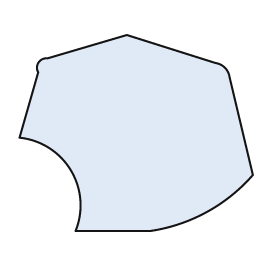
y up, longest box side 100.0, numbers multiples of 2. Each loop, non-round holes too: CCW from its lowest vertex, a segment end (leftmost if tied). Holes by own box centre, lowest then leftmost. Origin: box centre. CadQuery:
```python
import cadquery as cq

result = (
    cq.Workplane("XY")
    .moveTo(-26.0, -42.0)
    .lineTo(6.0, -42.0)
    .threePointArc((30.0, -34.0), (50.0, -18.0))
    .lineTo(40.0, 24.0)
    .threePointArc((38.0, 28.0), (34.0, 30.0))
    .lineTo(-4.0, 42.0)
    .lineTo(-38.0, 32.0)
    .threePointArc((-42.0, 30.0), (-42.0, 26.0))
    .lineTo(-50.0, -2.0)
    .threePointArc((-28.0, -16.0), (-26.0, -42.0))
    .close()
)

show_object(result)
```